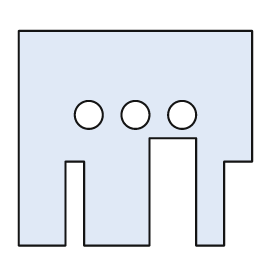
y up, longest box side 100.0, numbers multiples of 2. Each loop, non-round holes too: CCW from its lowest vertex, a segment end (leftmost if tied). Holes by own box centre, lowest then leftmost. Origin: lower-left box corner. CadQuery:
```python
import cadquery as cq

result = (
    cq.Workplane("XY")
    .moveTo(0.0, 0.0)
    .lineTo(20.0, 0.0)
    .lineTo(20.0, 36.0)
    .lineTo(28.0, 36.0)
    .lineTo(28.0, 0.0)
    .lineTo(56.0, 0.0)
    .lineTo(56.0, 46.0)
    .lineTo(76.0, 46.0)
    .lineTo(76.0, 0.0)
    .lineTo(88.0, 0.0)
    .lineTo(88.0, 36.0)
    .lineTo(100.0, 36.0)
    .lineTo(100.0, 92.0)
    .lineTo(0.0, 92.0)
    .close()
    .moveTo(30.0, 56.0)
    .circle(6.0)
    .moveTo(50.0, 56.0)
    .circle(6.0)
    .moveTo(70.0, 56.0)
    .circle(6.0)
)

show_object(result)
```